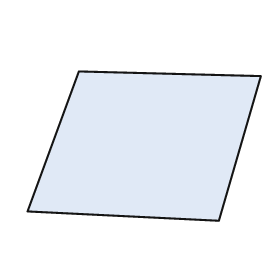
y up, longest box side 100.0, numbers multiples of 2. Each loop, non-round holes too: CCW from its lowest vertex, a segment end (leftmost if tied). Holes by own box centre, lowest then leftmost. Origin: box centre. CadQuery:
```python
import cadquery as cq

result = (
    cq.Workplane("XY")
    .moveTo(32.0, -32.0)
    .lineTo(50.0, 30.0)
    .lineTo(-28.0, 32.0)
    .lineTo(-50.0, -28.0)
    .close()
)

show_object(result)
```